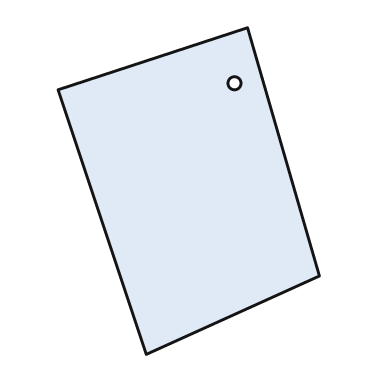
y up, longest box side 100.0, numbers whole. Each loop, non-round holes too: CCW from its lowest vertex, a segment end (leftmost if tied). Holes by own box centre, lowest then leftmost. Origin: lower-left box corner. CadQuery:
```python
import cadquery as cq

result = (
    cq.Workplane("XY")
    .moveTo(27.0, 0.0)
    .lineTo(80.0, 24.0)
    .lineTo(58.0, 100.0)
    .lineTo(0.0, 81.0)
    .close()
    .moveTo(54.0, 83.0)
    .circle(2.0)
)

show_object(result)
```